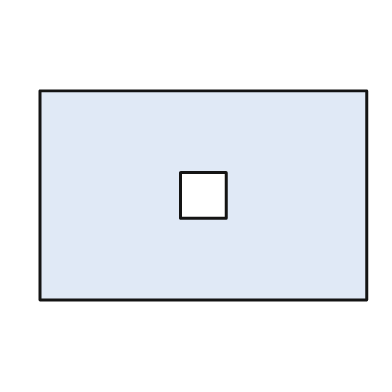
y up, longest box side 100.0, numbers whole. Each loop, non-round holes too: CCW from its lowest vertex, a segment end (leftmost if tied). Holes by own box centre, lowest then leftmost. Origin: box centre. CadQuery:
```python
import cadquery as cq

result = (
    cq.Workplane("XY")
    .moveTo(-50.0, -32.0)
    .lineTo(50.0, -32.0)
    .lineTo(50.0, 32.0)
    .lineTo(-50.0, 32.0)
    .close()
    .moveTo(-7.0, -7.0)
    .lineTo(7.0, -7.0)
    .lineTo(7.0, 7.0)
    .lineTo(-7.0, 7.0)
    .close()
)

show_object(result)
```